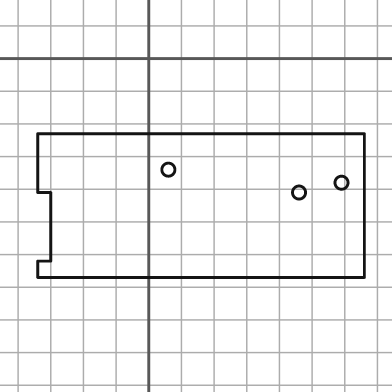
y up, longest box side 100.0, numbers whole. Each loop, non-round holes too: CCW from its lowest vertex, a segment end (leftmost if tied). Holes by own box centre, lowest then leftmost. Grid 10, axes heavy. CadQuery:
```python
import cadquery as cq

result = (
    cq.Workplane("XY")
    .moveTo(-34.0, -67.0)
    .lineTo(66.0, -67.0)
    .lineTo(66.0, -23.0)
    .lineTo(-34.0, -23.0)
    .lineTo(-34.0, -41.0)
    .lineTo(-30.0, -41.0)
    .lineTo(-30.0, -62.0)
    .lineTo(-34.0, -62.0)
    .close()
    .moveTo(46.0, -41.0)
    .circle(2.0)
    .moveTo(59.0, -38.0)
    .circle(2.0)
    .moveTo(6.0, -34.0)
    .circle(2.0)
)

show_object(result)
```